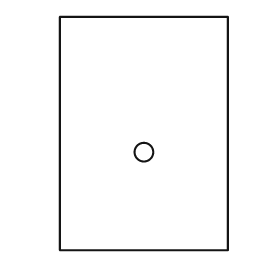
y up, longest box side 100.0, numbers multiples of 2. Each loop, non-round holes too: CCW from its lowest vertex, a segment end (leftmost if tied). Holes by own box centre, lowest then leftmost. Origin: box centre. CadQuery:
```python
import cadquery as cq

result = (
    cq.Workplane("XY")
    .moveTo(-36.0, -50.0)
    .lineTo(36.0, -50.0)
    .lineTo(36.0, 50.0)
    .lineTo(-36.0, 50.0)
    .close()
    .moveTo(0.0, -8.0)
    .circle(4.0)
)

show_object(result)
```